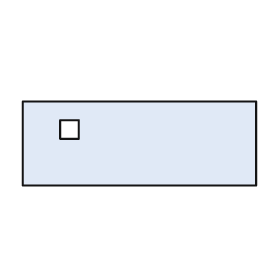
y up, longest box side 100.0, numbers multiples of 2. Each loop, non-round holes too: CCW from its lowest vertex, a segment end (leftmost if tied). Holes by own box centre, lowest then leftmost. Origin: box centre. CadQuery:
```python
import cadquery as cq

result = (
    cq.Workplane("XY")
    .moveTo(-50.0, -18.0)
    .lineTo(50.0, -18.0)
    .lineTo(50.0, 18.0)
    .lineTo(-50.0, 18.0)
    .close()
    .moveTo(-34.0, 2.0)
    .lineTo(-26.0, 2.0)
    .lineTo(-26.0, 10.0)
    .lineTo(-34.0, 10.0)
    .close()
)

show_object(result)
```